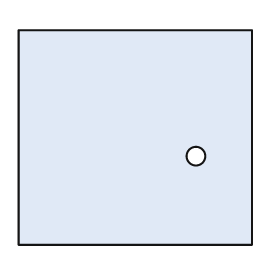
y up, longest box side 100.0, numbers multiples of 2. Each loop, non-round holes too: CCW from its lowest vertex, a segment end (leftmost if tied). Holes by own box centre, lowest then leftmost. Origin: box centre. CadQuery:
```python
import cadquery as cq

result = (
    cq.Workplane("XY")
    .moveTo(-50.0, -46.0)
    .lineTo(50.0, -46.0)
    .lineTo(50.0, 46.0)
    .lineTo(-50.0, 46.0)
    .close()
    .moveTo(26.0, -8.0)
    .circle(4.0)
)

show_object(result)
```